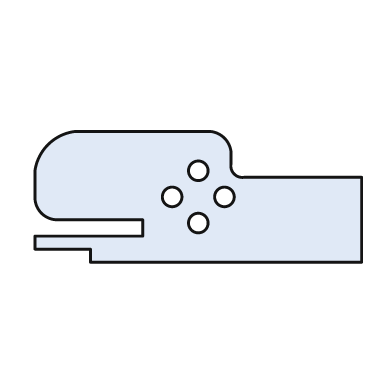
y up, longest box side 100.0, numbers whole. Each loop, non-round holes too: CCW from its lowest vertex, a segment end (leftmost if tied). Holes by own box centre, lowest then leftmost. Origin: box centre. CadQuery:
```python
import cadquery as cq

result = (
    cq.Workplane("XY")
    .moveTo(-33.0, -20.0)
    .lineTo(50.0, -20.0)
    .lineTo(50.0, 6.0)
    .lineTo(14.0, 6.0)
    .threePointArc((11.0, 7.0), (10.0, 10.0))
    .lineTo(10.0, 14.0)
    .threePointArc((8.0, 18.0), (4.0, 20.0))
    .lineTo(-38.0, 20.0)
    .threePointArc((-46.0, 16.0), (-50.0, 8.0))
    .lineTo(-50.0, 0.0)
    .threePointArc((-48.0, -5.0), (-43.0, -7.0))
    .lineTo(-17.0, -7.0)
    .lineTo(-17.0, -12.0)
    .lineTo(-50.0, -12.0)
    .lineTo(-50.0, -16.0)
    .lineTo(-33.0, -16.0)
    .close()
    .moveTo(0.0, -8.0)
    .circle(3.0)
    .moveTo(-8.0, 0.0)
    .circle(3.0)
    .moveTo(8.0, 0.0)
    .circle(3.0)
    .moveTo(0.0, 8.0)
    .circle(3.0)
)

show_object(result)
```